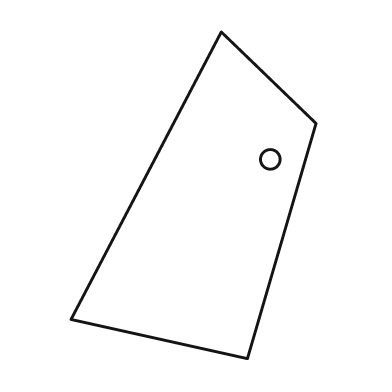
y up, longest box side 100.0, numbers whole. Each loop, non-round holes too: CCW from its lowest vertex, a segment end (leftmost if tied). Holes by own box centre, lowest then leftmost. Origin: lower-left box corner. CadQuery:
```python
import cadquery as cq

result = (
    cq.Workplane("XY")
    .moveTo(54.0, 0.0)
    .lineTo(75.0, 72.0)
    .lineTo(46.0, 100.0)
    .lineTo(0.0, 12.0)
    .close()
    .moveTo(61.0, 61.0)
    .circle(3.0)
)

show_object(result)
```